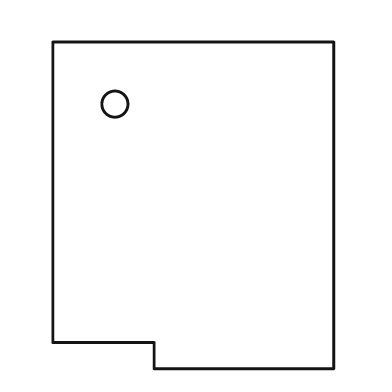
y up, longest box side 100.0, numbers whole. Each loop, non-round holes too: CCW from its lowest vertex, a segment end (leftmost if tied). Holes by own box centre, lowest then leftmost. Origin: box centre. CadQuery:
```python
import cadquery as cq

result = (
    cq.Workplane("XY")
    .moveTo(-12.0, -50.0)
    .lineTo(43.0, -50.0)
    .lineTo(43.0, 50.0)
    .lineTo(-43.0, 50.0)
    .lineTo(-43.0, -42.0)
    .lineTo(-12.0, -42.0)
    .close()
    .moveTo(-24.0, 31.0)
    .circle(4.0)
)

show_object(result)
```